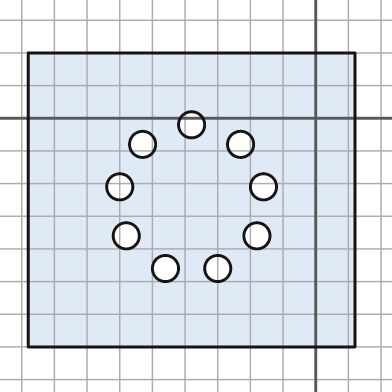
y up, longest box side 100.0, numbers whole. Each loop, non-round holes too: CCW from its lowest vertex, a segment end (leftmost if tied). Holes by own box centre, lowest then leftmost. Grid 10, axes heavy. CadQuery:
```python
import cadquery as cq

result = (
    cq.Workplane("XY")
    .moveTo(-88.0, -70.0)
    .lineTo(12.0, -70.0)
    .lineTo(12.0, 20.0)
    .lineTo(-88.0, 20.0)
    .close()
    .moveTo(-46.0, -46.0)
    .circle(4.0)
    .moveTo(-30.0, -46.0)
    .circle(4.0)
    .moveTo(-58.0, -36.0)
    .circle(4.0)
    .moveTo(-18.0, -36.0)
    .circle(4.0)
    .moveTo(-60.0, -21.0)
    .circle(4.0)
    .moveTo(-16.0, -21.0)
    .circle(4.0)
    .moveTo(-53.0, -8.0)
    .circle(4.0)
    .moveTo(-23.0, -8.0)
    .circle(4.0)
    .moveTo(-38.0, -2.0)
    .circle(4.0)
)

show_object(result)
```